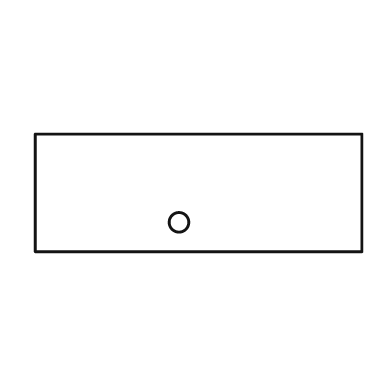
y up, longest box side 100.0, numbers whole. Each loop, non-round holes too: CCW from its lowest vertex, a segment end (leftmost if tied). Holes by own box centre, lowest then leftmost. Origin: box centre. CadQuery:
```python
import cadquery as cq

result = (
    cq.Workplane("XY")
    .moveTo(-50.0, -18.0)
    .lineTo(50.0, -18.0)
    .lineTo(50.0, 18.0)
    .lineTo(-50.0, 18.0)
    .close()
    .moveTo(-6.0, -9.0)
    .circle(3.0)
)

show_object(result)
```